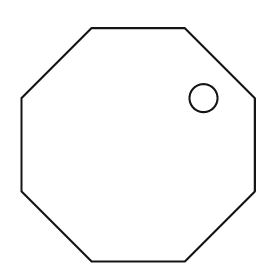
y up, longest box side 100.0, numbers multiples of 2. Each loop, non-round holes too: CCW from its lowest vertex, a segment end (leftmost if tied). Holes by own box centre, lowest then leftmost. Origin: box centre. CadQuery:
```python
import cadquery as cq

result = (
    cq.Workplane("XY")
    .moveTo(-20.0, -50.0)
    .lineTo(20.0, -50.0)
    .lineTo(50.0, -20.0)
    .lineTo(50.0, 20.0)
    .lineTo(20.0, 50.0)
    .lineTo(-20.0, 50.0)
    .lineTo(-50.0, 20.0)
    .lineTo(-50.0, -20.0)
    .close()
    .moveTo(28.0, 20.0)
    .circle(6.0)
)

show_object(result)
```